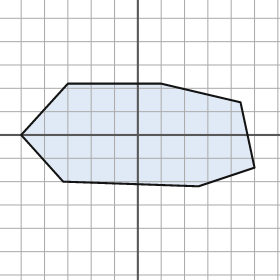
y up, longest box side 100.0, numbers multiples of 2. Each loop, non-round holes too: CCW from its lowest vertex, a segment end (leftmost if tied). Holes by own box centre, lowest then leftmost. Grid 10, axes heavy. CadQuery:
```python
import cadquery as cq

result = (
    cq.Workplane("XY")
    .moveTo(26.0, -22.0)
    .lineTo(50.0, -14.0)
    .lineTo(44.0, 14.0)
    .lineTo(10.0, 22.0)
    .lineTo(-30.0, 22.0)
    .lineTo(-50.0, 0.0)
    .lineTo(-32.0, -20.0)
    .close()
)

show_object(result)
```